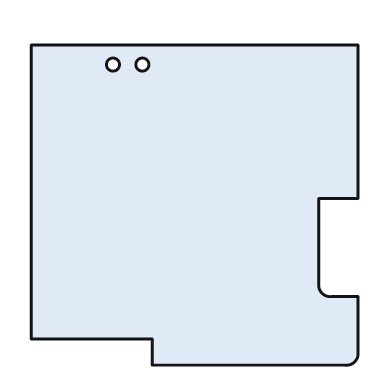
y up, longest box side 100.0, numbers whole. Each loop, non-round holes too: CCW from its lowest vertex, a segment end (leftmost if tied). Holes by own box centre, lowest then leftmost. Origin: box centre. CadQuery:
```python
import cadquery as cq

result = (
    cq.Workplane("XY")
    .moveTo(-13.0, -49.0)
    .lineTo(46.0, -49.0)
    .threePointArc((49.0, -48.0), (50.0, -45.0))
    .lineTo(50.0, -28.0)
    .lineTo(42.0, -28.0)
    .threePointArc((39.0, -27.0), (38.0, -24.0))
    .lineTo(38.0, 2.0)
    .lineTo(50.0, 2.0)
    .lineTo(50.0, 49.0)
    .lineTo(-50.0, 49.0)
    .lineTo(-50.0, -41.0)
    .lineTo(-13.0, -41.0)
    .close()
    .moveTo(-25.0, 43.0)
    .circle(2.0)
    .moveTo(-16.0, 43.0)
    .circle(2.0)
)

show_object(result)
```